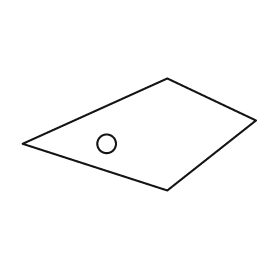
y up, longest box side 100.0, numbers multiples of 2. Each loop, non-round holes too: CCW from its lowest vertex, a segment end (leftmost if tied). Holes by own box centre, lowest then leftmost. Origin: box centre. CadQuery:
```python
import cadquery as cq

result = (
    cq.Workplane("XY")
    .moveTo(12.0, -24.0)
    .lineTo(50.0, 6.0)
    .lineTo(12.0, 24.0)
    .lineTo(-50.0, -4.0)
    .close()
    .moveTo(-14.0, -4.0)
    .circle(4.0)
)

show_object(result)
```